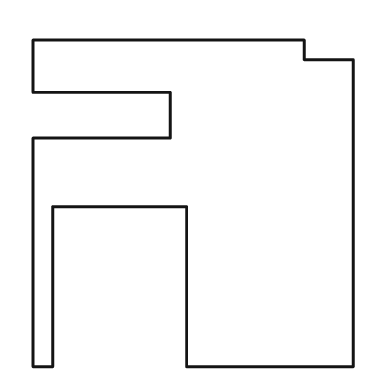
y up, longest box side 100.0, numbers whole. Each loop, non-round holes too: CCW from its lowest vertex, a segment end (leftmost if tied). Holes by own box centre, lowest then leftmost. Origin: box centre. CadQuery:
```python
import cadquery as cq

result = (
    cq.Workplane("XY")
    .moveTo(-49.0, -50.0)
    .lineTo(-43.0, -50.0)
    .lineTo(-43.0, -1.0)
    .lineTo(-2.0, -1.0)
    .lineTo(-2.0, -50.0)
    .lineTo(49.0, -50.0)
    .lineTo(49.0, 44.0)
    .lineTo(34.0, 44.0)
    .lineTo(34.0, 50.0)
    .lineTo(-49.0, 50.0)
    .lineTo(-49.0, 34.0)
    .lineTo(-7.0, 34.0)
    .lineTo(-7.0, 20.0)
    .lineTo(-49.0, 20.0)
    .close()
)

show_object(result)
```